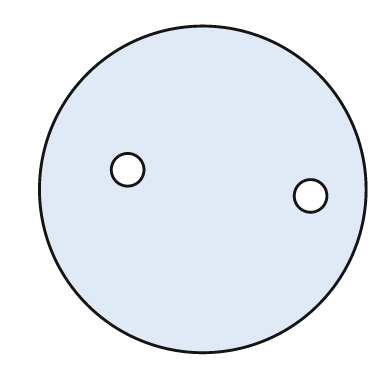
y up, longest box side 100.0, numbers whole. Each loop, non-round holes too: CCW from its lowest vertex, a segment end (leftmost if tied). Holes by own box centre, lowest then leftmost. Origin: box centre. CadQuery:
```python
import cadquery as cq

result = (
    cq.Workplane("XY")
    .moveTo(0.0, 0.0)
    .circle(50.0)
    .moveTo(33.0, -2.0)
    .circle(5.0)
    .moveTo(-23.0, 6.0)
    .circle(5.0)
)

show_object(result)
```